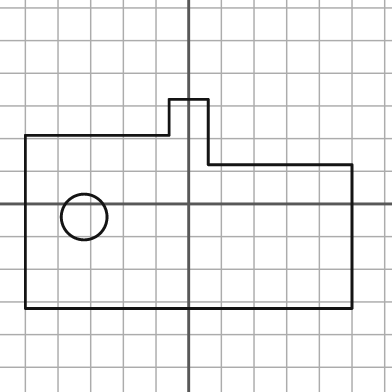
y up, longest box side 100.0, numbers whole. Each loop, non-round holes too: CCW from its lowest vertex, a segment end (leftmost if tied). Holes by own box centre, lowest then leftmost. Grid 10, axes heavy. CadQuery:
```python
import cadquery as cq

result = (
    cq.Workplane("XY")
    .moveTo(-50.0, -32.0)
    .lineTo(50.0, -32.0)
    .lineTo(50.0, 12.0)
    .lineTo(6.0, 12.0)
    .lineTo(6.0, 32.0)
    .lineTo(-6.0, 32.0)
    .lineTo(-6.0, 21.0)
    .lineTo(-50.0, 21.0)
    .close()
    .moveTo(-32.0, -4.0)
    .circle(7.0)
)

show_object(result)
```